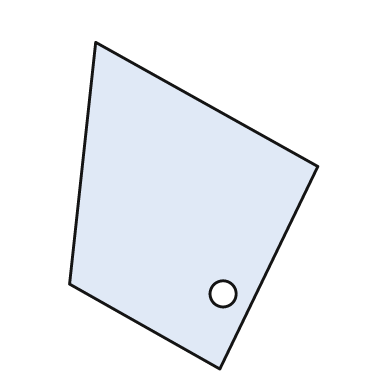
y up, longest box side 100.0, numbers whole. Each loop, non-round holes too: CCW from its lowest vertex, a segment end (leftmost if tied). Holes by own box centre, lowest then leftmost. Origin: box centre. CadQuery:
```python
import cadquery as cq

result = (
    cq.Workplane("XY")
    .moveTo(8.0, -50.0)
    .lineTo(38.0, 12.0)
    .lineTo(-30.0, 50.0)
    .lineTo(-38.0, -24.0)
    .close()
    .moveTo(9.0, -27.0)
    .circle(4.0)
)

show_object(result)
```